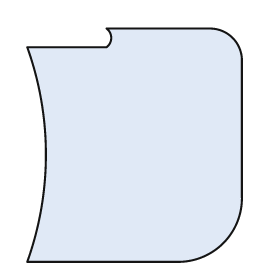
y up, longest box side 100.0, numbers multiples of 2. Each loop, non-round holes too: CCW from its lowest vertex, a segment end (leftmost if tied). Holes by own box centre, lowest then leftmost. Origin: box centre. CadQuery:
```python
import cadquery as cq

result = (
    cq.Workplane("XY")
    .moveTo(-46.0, -50.0)
    .lineTo(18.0, -50.0)
    .threePointArc((38.0, -42.0), (46.0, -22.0))
    .lineTo(46.0, 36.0)
    .threePointArc((42.0, 46.0), (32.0, 50.0))
    .lineTo(-12.0, 50.0)
    .threePointArc((-10.0, 46.0), (-12.0, 42.0))
    .lineTo(-46.0, 42.0)
    .threePointArc((-38.0, -4.0), (-46.0, -50.0))
    .close()
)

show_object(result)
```